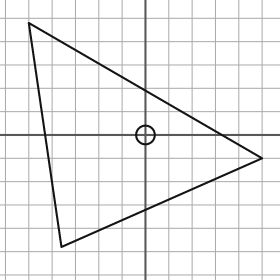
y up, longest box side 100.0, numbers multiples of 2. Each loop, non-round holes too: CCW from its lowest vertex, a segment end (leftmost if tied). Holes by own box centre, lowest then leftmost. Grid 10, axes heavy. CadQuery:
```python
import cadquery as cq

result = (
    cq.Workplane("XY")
    .moveTo(-36.0, -48.0)
    .lineTo(50.0, -10.0)
    .lineTo(-50.0, 48.0)
    .close()
    .moveTo(0.0, 0.0)
    .circle(4.0)
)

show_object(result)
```